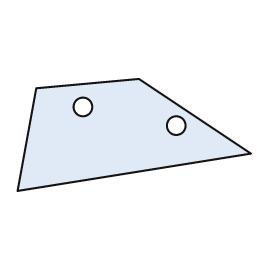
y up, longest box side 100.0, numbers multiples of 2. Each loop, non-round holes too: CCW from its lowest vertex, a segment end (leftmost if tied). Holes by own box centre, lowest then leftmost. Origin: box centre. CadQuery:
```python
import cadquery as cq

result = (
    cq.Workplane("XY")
    .moveTo(-50.0, -24.0)
    .lineTo(50.0, -8.0)
    .lineTo(2.0, 24.0)
    .lineTo(-42.0, 20.0)
    .close()
    .moveTo(18.0, 4.0)
    .circle(4.0)
    .moveTo(-22.0, 12.0)
    .circle(4.0)
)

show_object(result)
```